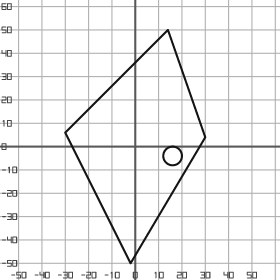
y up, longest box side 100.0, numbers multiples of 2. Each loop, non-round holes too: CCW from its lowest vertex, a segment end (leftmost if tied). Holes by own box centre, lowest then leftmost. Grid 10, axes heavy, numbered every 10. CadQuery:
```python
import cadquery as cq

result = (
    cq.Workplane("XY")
    .moveTo(-2.0, -50.0)
    .lineTo(30.0, 4.0)
    .lineTo(14.0, 50.0)
    .lineTo(-30.0, 6.0)
    .close()
    .moveTo(16.0, -4.0)
    .circle(4.0)
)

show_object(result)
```